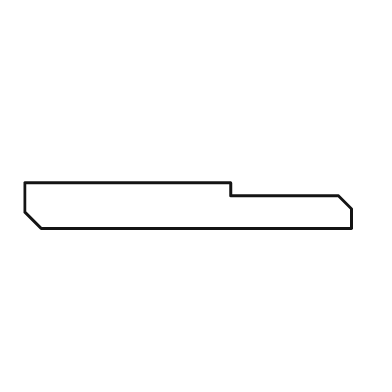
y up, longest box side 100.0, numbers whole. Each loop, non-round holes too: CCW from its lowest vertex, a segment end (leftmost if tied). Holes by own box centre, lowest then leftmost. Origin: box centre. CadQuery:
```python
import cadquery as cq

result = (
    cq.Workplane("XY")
    .moveTo(-45.0, -7.0)
    .lineTo(50.0, -7.0)
    .lineTo(50.0, -1.0)
    .lineTo(46.0, 3.0)
    .lineTo(13.0, 3.0)
    .lineTo(13.0, 7.0)
    .lineTo(-50.0, 7.0)
    .lineTo(-50.0, -2.0)
    .close()
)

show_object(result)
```